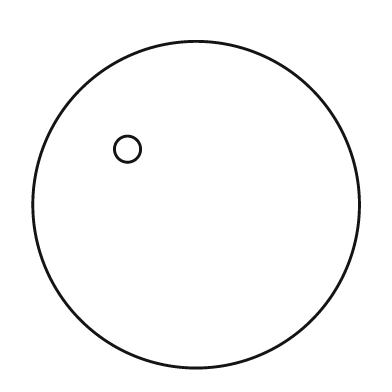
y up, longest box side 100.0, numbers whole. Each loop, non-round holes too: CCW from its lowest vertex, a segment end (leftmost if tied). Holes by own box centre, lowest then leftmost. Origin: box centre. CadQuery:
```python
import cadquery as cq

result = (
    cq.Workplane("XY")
    .moveTo(0.0, 0.0)
    .circle(50.0)
    .moveTo(-21.0, 17.0)
    .circle(4.0)
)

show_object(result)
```